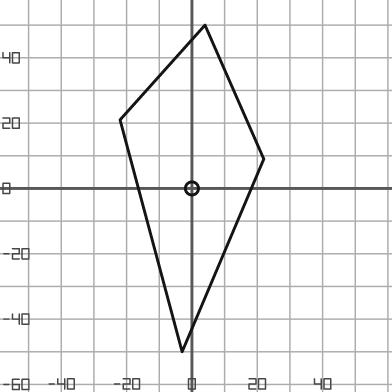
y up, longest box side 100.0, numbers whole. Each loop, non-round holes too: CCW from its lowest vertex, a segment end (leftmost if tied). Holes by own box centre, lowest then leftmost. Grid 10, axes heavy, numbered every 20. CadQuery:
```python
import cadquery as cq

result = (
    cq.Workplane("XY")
    .moveTo(-3.0, -50.0)
    .lineTo(22.0, 9.0)
    .lineTo(4.0, 50.0)
    .lineTo(-22.0, 21.0)
    .close()
    .moveTo(0.0, 0.0)
    .circle(2.0)
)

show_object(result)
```